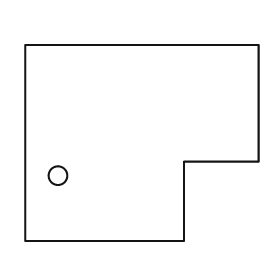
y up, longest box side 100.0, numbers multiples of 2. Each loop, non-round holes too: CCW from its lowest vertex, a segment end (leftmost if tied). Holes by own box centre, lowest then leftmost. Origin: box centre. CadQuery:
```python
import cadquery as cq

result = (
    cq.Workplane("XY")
    .moveTo(-50.0, -42.0)
    .lineTo(18.0, -42.0)
    .lineTo(18.0, -8.0)
    .lineTo(50.0, -8.0)
    .lineTo(50.0, 42.0)
    .lineTo(-50.0, 42.0)
    .close()
    .moveTo(-36.0, -14.0)
    .circle(4.0)
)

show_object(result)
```